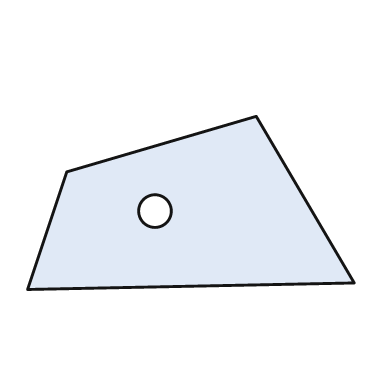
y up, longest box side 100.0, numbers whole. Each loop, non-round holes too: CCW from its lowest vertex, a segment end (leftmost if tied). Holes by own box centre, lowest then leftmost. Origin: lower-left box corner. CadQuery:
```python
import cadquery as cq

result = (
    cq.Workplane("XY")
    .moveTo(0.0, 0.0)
    .lineTo(100.0, 2.0)
    .lineTo(70.0, 53.0)
    .lineTo(12.0, 36.0)
    .close()
    .moveTo(39.0, 24.0)
    .circle(5.0)
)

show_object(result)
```